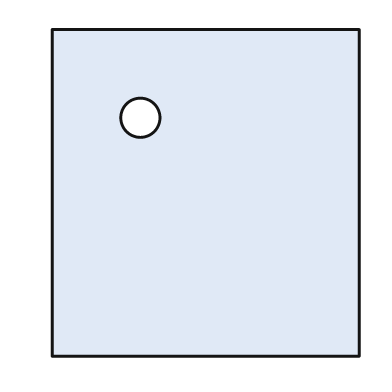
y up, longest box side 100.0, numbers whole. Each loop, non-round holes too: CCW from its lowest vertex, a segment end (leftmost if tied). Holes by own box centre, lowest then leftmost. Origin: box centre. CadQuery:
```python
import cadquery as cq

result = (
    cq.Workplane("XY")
    .moveTo(-47.0, -50.0)
    .lineTo(47.0, -50.0)
    .lineTo(47.0, 50.0)
    .lineTo(-47.0, 50.0)
    .close()
    .moveTo(-20.0, 23.0)
    .circle(6.0)
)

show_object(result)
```